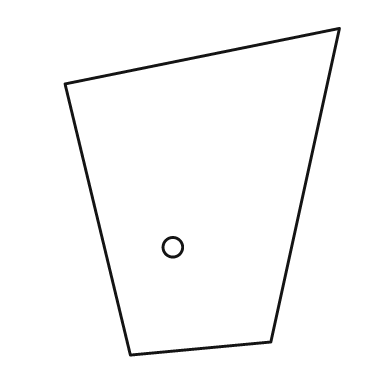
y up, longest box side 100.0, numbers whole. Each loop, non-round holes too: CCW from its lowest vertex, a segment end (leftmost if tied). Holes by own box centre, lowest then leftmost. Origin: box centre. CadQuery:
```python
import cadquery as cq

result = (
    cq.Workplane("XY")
    .moveTo(-22.0, -50.0)
    .lineTo(21.0, -46.0)
    .lineTo(42.0, 50.0)
    .lineTo(-42.0, 33.0)
    .close()
    .moveTo(-9.0, -17.0)
    .circle(3.0)
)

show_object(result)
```